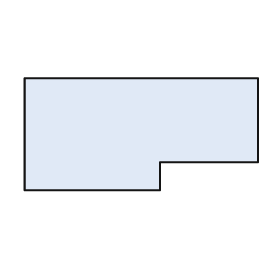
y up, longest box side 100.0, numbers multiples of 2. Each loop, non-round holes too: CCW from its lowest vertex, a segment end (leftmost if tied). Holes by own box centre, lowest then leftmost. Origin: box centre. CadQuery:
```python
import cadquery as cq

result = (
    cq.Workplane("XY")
    .moveTo(-50.0, -24.0)
    .lineTo(8.0, -24.0)
    .lineTo(8.0, -12.0)
    .lineTo(50.0, -12.0)
    .lineTo(50.0, 24.0)
    .lineTo(-50.0, 24.0)
    .close()
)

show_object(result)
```